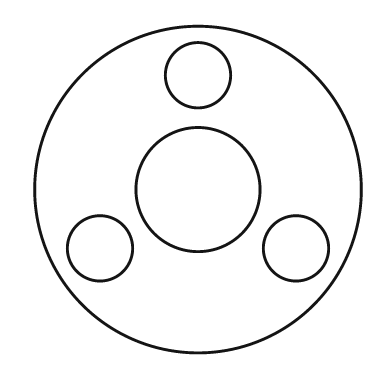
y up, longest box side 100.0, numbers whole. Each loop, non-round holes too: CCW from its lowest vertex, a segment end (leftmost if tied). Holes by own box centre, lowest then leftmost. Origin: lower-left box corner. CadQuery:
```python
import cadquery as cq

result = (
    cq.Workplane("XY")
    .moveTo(50.0, 50.0)
    .circle(50.0)
    .moveTo(20.0, 32.0)
    .circle(10.0)
    .moveTo(80.0, 32.0)
    .circle(10.0)
    .moveTo(50.0, 50.0)
    .circle(19.0)
    .moveTo(50.0, 85.0)
    .circle(10.0)
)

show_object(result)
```